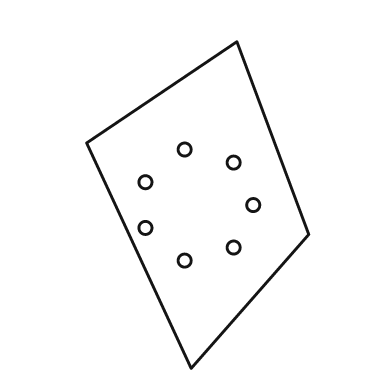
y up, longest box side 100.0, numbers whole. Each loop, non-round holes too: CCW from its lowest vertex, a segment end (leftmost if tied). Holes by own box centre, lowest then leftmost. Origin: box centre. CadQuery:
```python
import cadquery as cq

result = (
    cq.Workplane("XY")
    .moveTo(-2.0, -50.0)
    .lineTo(34.0, -9.0)
    .lineTo(12.0, 50.0)
    .lineTo(-34.0, 19.0)
    .close()
    .moveTo(-4.0, -17.0)
    .circle(2.0)
    .moveTo(11.0, -13.0)
    .circle(2.0)
    .moveTo(-16.0, -7.0)
    .circle(2.0)
    .moveTo(17.0, 0.0)
    .circle(2.0)
    .moveTo(-16.0, 7.0)
    .circle(2.0)
    .moveTo(11.0, 13.0)
    .circle(2.0)
    .moveTo(-4.0, 17.0)
    .circle(2.0)
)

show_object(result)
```